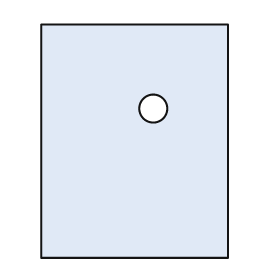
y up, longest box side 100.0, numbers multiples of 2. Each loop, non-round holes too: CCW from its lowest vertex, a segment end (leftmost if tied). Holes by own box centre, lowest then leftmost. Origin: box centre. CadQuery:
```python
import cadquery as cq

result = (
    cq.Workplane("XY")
    .moveTo(-40.0, -50.0)
    .lineTo(40.0, -50.0)
    .lineTo(40.0, 50.0)
    .lineTo(-40.0, 50.0)
    .close()
    .moveTo(8.0, 14.0)
    .circle(6.0)
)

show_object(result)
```